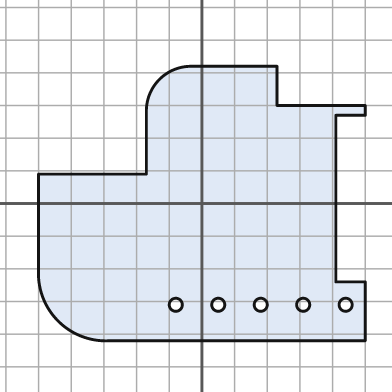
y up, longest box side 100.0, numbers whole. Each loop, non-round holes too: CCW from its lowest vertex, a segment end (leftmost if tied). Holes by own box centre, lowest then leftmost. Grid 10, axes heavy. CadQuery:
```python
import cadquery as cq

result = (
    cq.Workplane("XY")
    .moveTo(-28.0, -42.0)
    .lineTo(50.0, -42.0)
    .lineTo(50.0, -24.0)
    .lineTo(41.0, -24.0)
    .lineTo(41.0, 27.0)
    .lineTo(50.0, 27.0)
    .lineTo(50.0, 30.0)
    .lineTo(23.0, 30.0)
    .lineTo(23.0, 42.0)
    .lineTo(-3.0, 42.0)
    .threePointArc((-13.0, 38.0), (-17.0, 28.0))
    .lineTo(-17.0, 9.0)
    .lineTo(-50.0, 9.0)
    .lineTo(-50.0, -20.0)
    .threePointArc((-44.0, -36.0), (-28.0, -42.0))
    .close()
    .moveTo(-8.0, -31.0)
    .circle(2.0)
    .moveTo(5.0, -31.0)
    .circle(2.0)
    .moveTo(18.0, -31.0)
    .circle(2.0)
    .moveTo(31.0, -31.0)
    .circle(2.0)
    .moveTo(44.0, -31.0)
    .circle(2.0)
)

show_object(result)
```